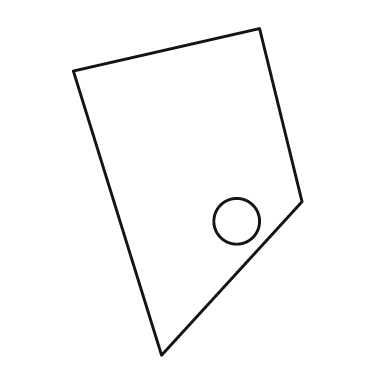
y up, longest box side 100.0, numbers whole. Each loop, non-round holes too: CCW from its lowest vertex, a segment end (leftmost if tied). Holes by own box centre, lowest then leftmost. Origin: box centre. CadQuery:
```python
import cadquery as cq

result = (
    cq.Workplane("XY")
    .moveTo(-8.0, -50.0)
    .lineTo(35.0, -3.0)
    .lineTo(22.0, 50.0)
    .lineTo(-35.0, 37.0)
    .close()
    .moveTo(15.0, -9.0)
    .circle(7.0)
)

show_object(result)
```